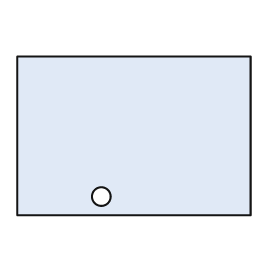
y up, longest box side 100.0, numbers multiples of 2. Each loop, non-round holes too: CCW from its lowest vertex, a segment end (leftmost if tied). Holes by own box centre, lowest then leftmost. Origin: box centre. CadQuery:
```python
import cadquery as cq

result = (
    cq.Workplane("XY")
    .moveTo(-50.0, -34.0)
    .lineTo(50.0, -34.0)
    .lineTo(50.0, 34.0)
    .lineTo(-50.0, 34.0)
    .close()
    .moveTo(-14.0, -26.0)
    .circle(4.0)
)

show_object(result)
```